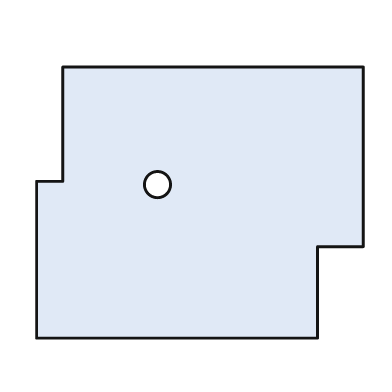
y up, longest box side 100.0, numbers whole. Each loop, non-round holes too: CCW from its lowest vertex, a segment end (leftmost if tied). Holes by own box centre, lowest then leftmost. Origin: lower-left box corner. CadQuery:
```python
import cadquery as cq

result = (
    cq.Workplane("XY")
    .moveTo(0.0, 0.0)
    .lineTo(86.0, 0.0)
    .lineTo(86.0, 28.0)
    .lineTo(100.0, 28.0)
    .lineTo(100.0, 83.0)
    .lineTo(8.0, 83.0)
    .lineTo(8.0, 48.0)
    .lineTo(0.0, 48.0)
    .close()
    .moveTo(37.0, 47.0)
    .circle(4.0)
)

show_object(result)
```